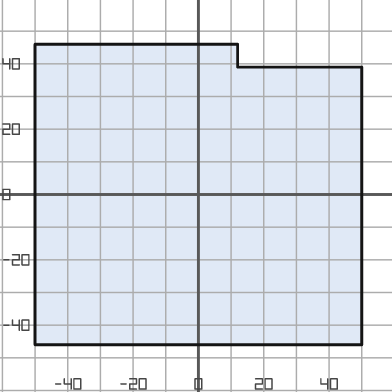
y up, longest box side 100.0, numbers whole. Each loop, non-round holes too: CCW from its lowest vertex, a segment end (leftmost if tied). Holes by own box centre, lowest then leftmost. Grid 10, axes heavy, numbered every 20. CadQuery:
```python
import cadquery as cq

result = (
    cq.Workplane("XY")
    .moveTo(-50.0, -46.0)
    .lineTo(50.0, -46.0)
    .lineTo(50.0, 39.0)
    .lineTo(12.0, 39.0)
    .lineTo(12.0, 46.0)
    .lineTo(-50.0, 46.0)
    .close()
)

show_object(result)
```